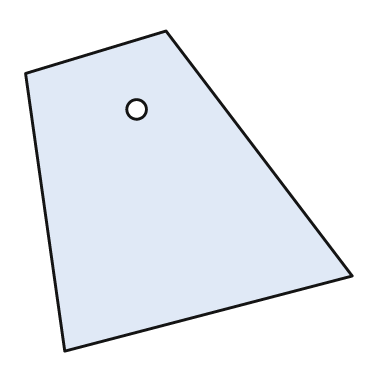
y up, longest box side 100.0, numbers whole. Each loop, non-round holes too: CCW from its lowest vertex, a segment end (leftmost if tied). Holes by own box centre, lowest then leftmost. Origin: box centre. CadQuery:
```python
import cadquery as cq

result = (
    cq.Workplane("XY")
    .moveTo(-38.0, -49.0)
    .lineTo(50.0, -26.0)
    .lineTo(-7.0, 49.0)
    .lineTo(-50.0, 36.0)
    .close()
    .moveTo(-16.0, 25.0)
    .circle(3.0)
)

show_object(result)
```